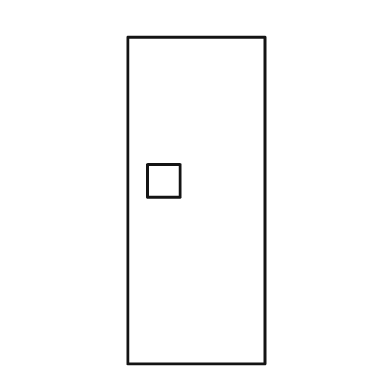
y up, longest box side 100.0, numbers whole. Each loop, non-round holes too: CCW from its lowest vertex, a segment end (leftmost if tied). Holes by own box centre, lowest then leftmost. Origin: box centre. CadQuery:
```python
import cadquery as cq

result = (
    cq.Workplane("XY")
    .moveTo(-21.0, -50.0)
    .lineTo(21.0, -50.0)
    .lineTo(21.0, 50.0)
    .lineTo(-21.0, 50.0)
    .close()
    .moveTo(-15.0, 1.0)
    .lineTo(-5.0, 1.0)
    .lineTo(-5.0, 11.0)
    .lineTo(-15.0, 11.0)
    .close()
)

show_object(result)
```